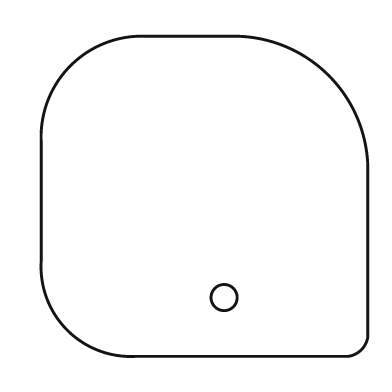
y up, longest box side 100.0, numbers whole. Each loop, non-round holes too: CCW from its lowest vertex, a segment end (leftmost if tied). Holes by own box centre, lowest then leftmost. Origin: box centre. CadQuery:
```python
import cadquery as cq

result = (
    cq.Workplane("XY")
    .moveTo(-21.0, -49.0)
    .lineTo(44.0, -49.0)
    .threePointArc((48.0, -47.0), (50.0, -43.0))
    .lineTo(50.0, 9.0)
    .threePointArc((38.0, 37.0), (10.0, 49.0))
    .lineTo(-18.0, 49.0)
    .threePointArc((-41.0, 40.0), (-50.0, 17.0))
    .lineTo(-50.0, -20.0)
    .threePointArc((-42.0, -41.0), (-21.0, -49.0))
    .close()
    .moveTo(6.0, -31.0)
    .circle(4.0)
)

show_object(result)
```